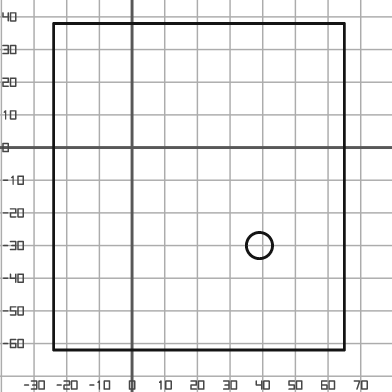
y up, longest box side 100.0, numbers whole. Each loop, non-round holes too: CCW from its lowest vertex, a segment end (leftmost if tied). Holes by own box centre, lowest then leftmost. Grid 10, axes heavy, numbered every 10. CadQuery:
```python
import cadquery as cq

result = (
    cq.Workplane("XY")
    .moveTo(-24.0, -62.0)
    .lineTo(65.0, -62.0)
    .lineTo(65.0, 38.0)
    .lineTo(-24.0, 38.0)
    .close()
    .moveTo(39.0, -30.0)
    .circle(4.0)
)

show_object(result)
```